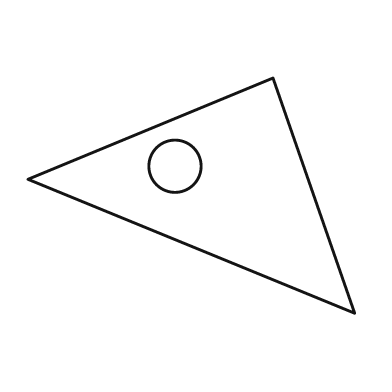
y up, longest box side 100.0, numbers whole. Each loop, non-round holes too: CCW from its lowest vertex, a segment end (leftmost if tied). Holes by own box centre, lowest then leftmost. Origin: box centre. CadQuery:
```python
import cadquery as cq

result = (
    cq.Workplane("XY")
    .moveTo(50.0, -36.0)
    .lineTo(25.0, 36.0)
    .lineTo(-50.0, 5.0)
    .close()
    .moveTo(-5.0, 9.0)
    .circle(8.0)
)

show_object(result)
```